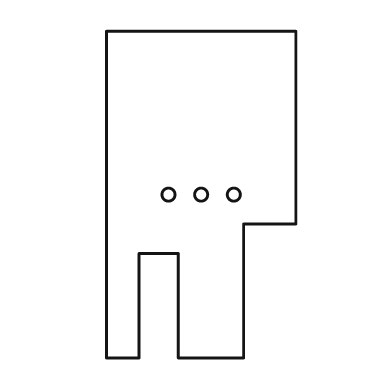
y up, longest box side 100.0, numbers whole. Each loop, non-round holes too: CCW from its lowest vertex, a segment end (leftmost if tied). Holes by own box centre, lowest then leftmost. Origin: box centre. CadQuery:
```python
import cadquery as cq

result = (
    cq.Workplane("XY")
    .moveTo(-29.0, -50.0)
    .lineTo(-19.0, -50.0)
    .lineTo(-19.0, -18.0)
    .lineTo(-7.0, -18.0)
    .lineTo(-7.0, -50.0)
    .lineTo(13.0, -50.0)
    .lineTo(13.0, -9.0)
    .lineTo(29.0, -9.0)
    .lineTo(29.0, 50.0)
    .lineTo(-29.0, 50.0)
    .close()
    .moveTo(-10.0, 0.0)
    .circle(2.0)
    .moveTo(0.0, 0.0)
    .circle(2.0)
    .moveTo(10.0, 0.0)
    .circle(2.0)
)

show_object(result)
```